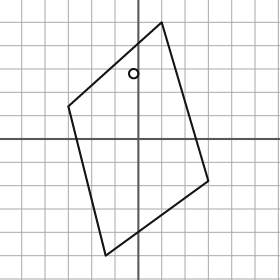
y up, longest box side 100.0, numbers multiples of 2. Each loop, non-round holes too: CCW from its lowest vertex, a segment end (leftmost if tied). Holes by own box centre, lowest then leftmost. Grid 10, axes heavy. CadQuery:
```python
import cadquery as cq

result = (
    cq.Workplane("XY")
    .moveTo(-14.0, -50.0)
    .lineTo(30.0, -18.0)
    .lineTo(10.0, 50.0)
    .lineTo(-30.0, 14.0)
    .close()
    .moveTo(-2.0, 28.0)
    .circle(2.0)
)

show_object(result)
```